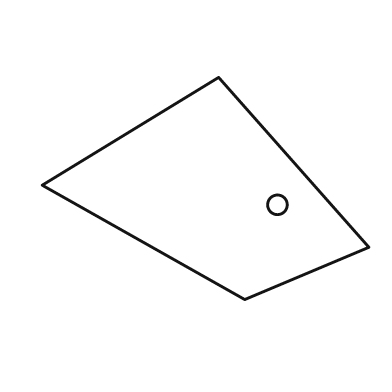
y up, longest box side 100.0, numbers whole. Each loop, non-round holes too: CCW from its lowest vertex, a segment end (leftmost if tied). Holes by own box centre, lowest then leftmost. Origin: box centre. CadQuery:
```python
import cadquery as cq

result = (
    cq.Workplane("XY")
    .moveTo(12.0, -34.0)
    .lineTo(50.0, -18.0)
    .lineTo(4.0, 34.0)
    .lineTo(-50.0, 1.0)
    .close()
    .moveTo(22.0, -5.0)
    .circle(3.0)
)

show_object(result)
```